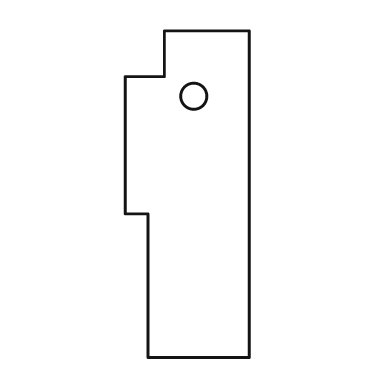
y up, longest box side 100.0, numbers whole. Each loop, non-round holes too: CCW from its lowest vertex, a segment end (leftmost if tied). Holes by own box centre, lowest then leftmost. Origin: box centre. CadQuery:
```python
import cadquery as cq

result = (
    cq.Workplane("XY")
    .moveTo(-12.0, -50.0)
    .lineTo(19.0, -50.0)
    .lineTo(19.0, 50.0)
    .lineTo(-7.0, 50.0)
    .lineTo(-7.0, 36.0)
    .lineTo(-19.0, 36.0)
    .lineTo(-19.0, -6.0)
    .lineTo(-12.0, -6.0)
    .close()
    .moveTo(2.0, 30.0)
    .circle(4.0)
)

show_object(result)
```